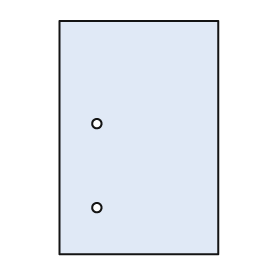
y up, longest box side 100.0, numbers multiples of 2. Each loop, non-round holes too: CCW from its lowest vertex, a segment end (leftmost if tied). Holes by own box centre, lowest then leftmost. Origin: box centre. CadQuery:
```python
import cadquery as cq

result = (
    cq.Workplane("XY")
    .moveTo(-34.0, -50.0)
    .lineTo(34.0, -50.0)
    .lineTo(34.0, 50.0)
    .lineTo(-34.0, 50.0)
    .close()
    .moveTo(-18.0, -30.0)
    .circle(2.0)
    .moveTo(-18.0, 6.0)
    .circle(2.0)
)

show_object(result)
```